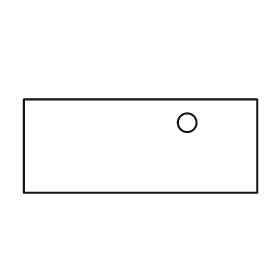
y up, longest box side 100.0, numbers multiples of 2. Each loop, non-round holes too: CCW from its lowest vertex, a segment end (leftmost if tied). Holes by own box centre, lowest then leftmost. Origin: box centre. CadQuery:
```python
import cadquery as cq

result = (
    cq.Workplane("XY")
    .moveTo(-50.0, -20.0)
    .lineTo(50.0, -20.0)
    .lineTo(50.0, 20.0)
    .lineTo(-50.0, 20.0)
    .close()
    .moveTo(20.0, 10.0)
    .circle(4.0)
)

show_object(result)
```